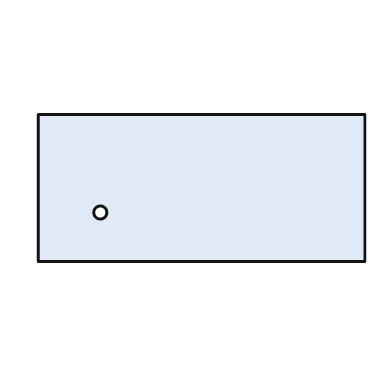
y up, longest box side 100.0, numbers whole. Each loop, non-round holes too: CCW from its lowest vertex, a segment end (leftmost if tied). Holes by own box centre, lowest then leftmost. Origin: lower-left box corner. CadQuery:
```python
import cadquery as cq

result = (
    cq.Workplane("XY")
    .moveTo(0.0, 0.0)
    .lineTo(100.0, 0.0)
    .lineTo(100.0, 45.0)
    .lineTo(0.0, 45.0)
    .close()
    .moveTo(19.0, 15.0)
    .circle(2.0)
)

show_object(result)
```